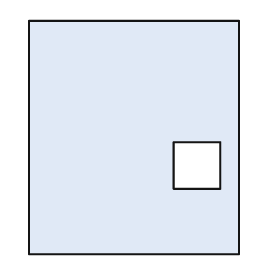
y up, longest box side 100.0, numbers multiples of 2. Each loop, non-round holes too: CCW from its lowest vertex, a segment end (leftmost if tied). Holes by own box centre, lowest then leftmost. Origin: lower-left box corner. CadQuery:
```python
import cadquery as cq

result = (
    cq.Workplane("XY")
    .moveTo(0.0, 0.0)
    .lineTo(90.0, 0.0)
    .lineTo(90.0, 100.0)
    .lineTo(0.0, 100.0)
    .close()
    .moveTo(62.0, 28.0)
    .lineTo(82.0, 28.0)
    .lineTo(82.0, 48.0)
    .lineTo(62.0, 48.0)
    .close()
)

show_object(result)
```